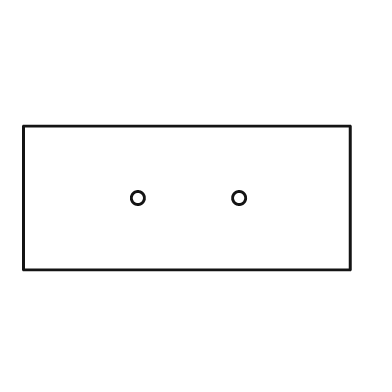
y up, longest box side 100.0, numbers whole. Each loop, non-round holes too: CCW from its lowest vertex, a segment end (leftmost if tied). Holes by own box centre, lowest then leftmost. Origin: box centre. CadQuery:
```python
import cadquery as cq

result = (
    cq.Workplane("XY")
    .moveTo(-50.0, -22.0)
    .lineTo(50.0, -22.0)
    .lineTo(50.0, 22.0)
    .lineTo(-50.0, 22.0)
    .close()
    .moveTo(-15.0, 0.0)
    .circle(2.0)
    .moveTo(16.0, 0.0)
    .circle(2.0)
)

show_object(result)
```